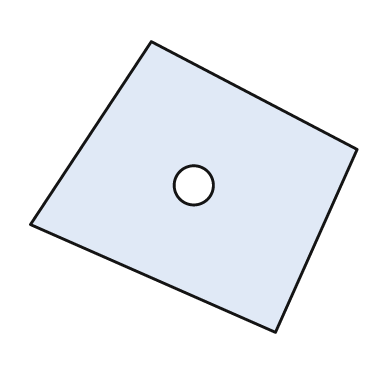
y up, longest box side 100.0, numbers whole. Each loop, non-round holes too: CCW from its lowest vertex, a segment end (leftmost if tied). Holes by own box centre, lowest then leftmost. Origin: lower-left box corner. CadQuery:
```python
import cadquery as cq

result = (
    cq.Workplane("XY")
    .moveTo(75.0, 0.0)
    .lineTo(100.0, 56.0)
    .lineTo(37.0, 89.0)
    .lineTo(0.0, 33.0)
    .close()
    .moveTo(50.0, 45.0)
    .circle(6.0)
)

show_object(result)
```